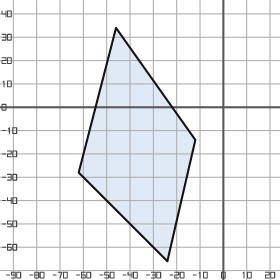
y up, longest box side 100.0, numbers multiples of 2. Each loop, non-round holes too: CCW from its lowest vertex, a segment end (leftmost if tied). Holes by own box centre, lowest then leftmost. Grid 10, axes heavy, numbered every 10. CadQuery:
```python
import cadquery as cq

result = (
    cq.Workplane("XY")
    .moveTo(-24.0, -66.0)
    .lineTo(-12.0, -14.0)
    .lineTo(-46.0, 34.0)
    .lineTo(-62.0, -28.0)
    .close()
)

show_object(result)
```